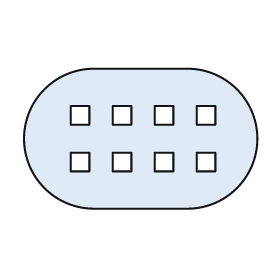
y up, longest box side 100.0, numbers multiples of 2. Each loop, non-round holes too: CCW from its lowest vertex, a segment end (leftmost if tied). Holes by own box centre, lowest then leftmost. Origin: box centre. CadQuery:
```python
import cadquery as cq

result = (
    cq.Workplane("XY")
    .moveTo(-20.0, -30.0)
    .lineTo(20.0, -30.0)
    .threePointArc((50.0, 0.0), (20.0, 30.0))
    .lineTo(-20.0, 30.0)
    .threePointArc((-50.0, 0.0), (-20.0, -30.0))
    .close()
    .moveTo(-30.0, -14.0)
    .lineTo(-22.0, -14.0)
    .lineTo(-22.0, -6.0)
    .lineTo(-30.0, -6.0)
    .close()
    .moveTo(-12.0, -14.0)
    .lineTo(-4.0, -14.0)
    .lineTo(-4.0, -6.0)
    .lineTo(-12.0, -6.0)
    .close()
    .moveTo(6.0, -14.0)
    .lineTo(14.0, -14.0)
    .lineTo(14.0, -6.0)
    .lineTo(6.0, -6.0)
    .close()
    .moveTo(24.0, -14.0)
    .lineTo(32.0, -14.0)
    .lineTo(32.0, -6.0)
    .lineTo(24.0, -6.0)
    .close()
    .moveTo(-30.0, 6.0)
    .lineTo(-22.0, 6.0)
    .lineTo(-22.0, 14.0)
    .lineTo(-30.0, 14.0)
    .close()
    .moveTo(-12.0, 6.0)
    .lineTo(-4.0, 6.0)
    .lineTo(-4.0, 14.0)
    .lineTo(-12.0, 14.0)
    .close()
    .moveTo(6.0, 6.0)
    .lineTo(14.0, 6.0)
    .lineTo(14.0, 14.0)
    .lineTo(6.0, 14.0)
    .close()
    .moveTo(24.0, 6.0)
    .lineTo(32.0, 6.0)
    .lineTo(32.0, 14.0)
    .lineTo(24.0, 14.0)
    .close()
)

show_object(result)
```